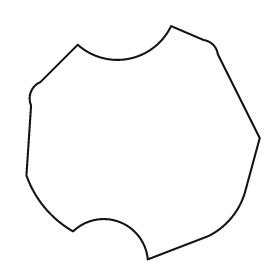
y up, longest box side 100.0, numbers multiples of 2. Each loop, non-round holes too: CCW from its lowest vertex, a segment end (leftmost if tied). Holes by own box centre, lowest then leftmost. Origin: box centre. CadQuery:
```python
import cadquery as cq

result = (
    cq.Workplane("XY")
    .moveTo(2.0, -50.0)
    .lineTo(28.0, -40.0)
    .threePointArc((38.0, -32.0), (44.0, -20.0))
    .lineTo(50.0, 2.0)
    .lineTo(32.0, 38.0)
    .threePointArc((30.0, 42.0), (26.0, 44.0))
    .lineTo(12.0, 50.0)
    .threePointArc((-6.0, 36.0), (-28.0, 42.0))
    .lineTo(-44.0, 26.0)
    .threePointArc((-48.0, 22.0), (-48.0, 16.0))
    .lineTo(-50.0, -14.0)
    .threePointArc((-42.0, -28.0), (-30.0, -38.0))
    .threePointArc((-10.0, -34.0), (2.0, -50.0))
    .close()
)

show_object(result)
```